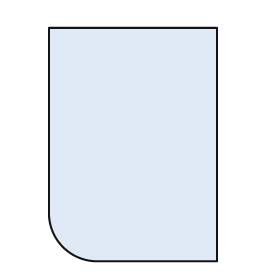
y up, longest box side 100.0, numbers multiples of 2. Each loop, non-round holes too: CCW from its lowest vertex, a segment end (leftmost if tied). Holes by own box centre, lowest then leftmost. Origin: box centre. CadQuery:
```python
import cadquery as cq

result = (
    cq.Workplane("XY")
    .moveTo(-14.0, -50.0)
    .lineTo(36.0, -50.0)
    .lineTo(36.0, 50.0)
    .lineTo(-36.0, 50.0)
    .lineTo(-36.0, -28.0)
    .threePointArc((-30.0, -44.0), (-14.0, -50.0))
    .close()
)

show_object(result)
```